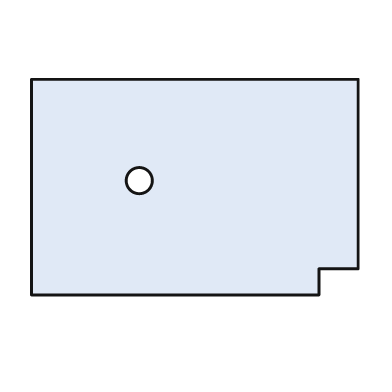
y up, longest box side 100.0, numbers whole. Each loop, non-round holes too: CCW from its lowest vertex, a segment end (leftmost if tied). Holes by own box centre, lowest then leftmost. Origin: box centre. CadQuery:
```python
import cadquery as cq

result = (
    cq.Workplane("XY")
    .moveTo(-50.0, -33.0)
    .lineTo(38.0, -33.0)
    .lineTo(38.0, -25.0)
    .lineTo(50.0, -25.0)
    .lineTo(50.0, 33.0)
    .lineTo(-50.0, 33.0)
    .close()
    .moveTo(-17.0, 2.0)
    .circle(4.0)
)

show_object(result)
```